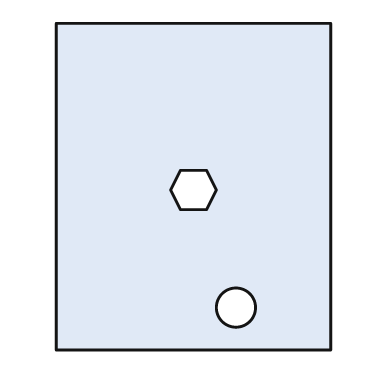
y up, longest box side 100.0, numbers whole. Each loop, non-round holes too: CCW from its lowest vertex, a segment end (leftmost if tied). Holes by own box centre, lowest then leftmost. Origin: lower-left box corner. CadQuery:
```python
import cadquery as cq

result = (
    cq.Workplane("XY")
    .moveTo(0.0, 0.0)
    .lineTo(84.0, 0.0)
    .lineTo(84.0, 100.0)
    .lineTo(0.0, 100.0)
    .close()
    .moveTo(55.0, 13.0)
    .circle(6.0)
    .moveTo(38.0, 43.0)
    .lineTo(46.0, 43.0)
    .lineTo(49.0, 49.0)
    .lineTo(46.0, 55.0)
    .lineTo(38.0, 55.0)
    .lineTo(35.0, 49.0)
    .close()
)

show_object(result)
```